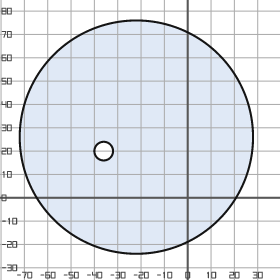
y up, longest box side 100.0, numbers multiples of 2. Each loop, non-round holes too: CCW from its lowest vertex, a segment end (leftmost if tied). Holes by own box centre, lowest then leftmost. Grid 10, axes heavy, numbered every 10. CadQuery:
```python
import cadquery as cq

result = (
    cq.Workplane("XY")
    .moveTo(-22.0, 26.0)
    .circle(50.0)
    .moveTo(-36.0, 20.0)
    .circle(4.0)
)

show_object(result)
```